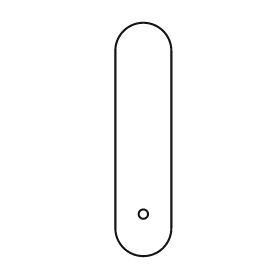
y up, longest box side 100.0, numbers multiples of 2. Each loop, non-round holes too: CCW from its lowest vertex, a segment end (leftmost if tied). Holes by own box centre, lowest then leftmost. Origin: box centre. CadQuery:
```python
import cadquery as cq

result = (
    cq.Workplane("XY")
    .moveTo(-12.0, -38.0)
    .threePointArc((0.0, -50.0), (12.0, -38.0))
    .lineTo(12.0, 38.0)
    .threePointArc((0.0, 50.0), (-12.0, 38.0))
    .close()
    .moveTo(0.0, -32.0)
    .circle(2.0)
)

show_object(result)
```